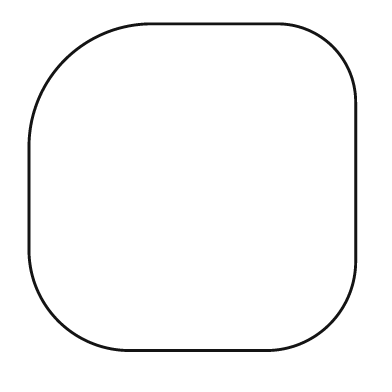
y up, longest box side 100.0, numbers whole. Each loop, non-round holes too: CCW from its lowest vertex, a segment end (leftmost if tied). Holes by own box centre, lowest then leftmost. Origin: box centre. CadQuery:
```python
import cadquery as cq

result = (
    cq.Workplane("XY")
    .moveTo(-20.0, -50.0)
    .lineTo(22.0, -50.0)
    .threePointArc((42.0, -42.0), (50.0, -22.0))
    .lineTo(50.0, 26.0)
    .threePointArc((43.0, 43.0), (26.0, 50.0))
    .lineTo(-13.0, 50.0)
    .threePointArc((-39.0, 39.0), (-50.0, 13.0))
    .lineTo(-50.0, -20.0)
    .threePointArc((-41.0, -41.0), (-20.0, -50.0))
    .close()
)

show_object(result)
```